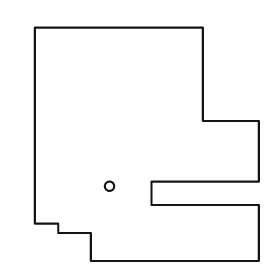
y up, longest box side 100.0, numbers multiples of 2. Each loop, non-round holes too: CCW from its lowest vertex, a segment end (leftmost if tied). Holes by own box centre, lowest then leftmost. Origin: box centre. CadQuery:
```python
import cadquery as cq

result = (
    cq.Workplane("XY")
    .moveTo(-24.0, -50.0)
    .lineTo(48.0, -50.0)
    .lineTo(48.0, -26.0)
    .lineTo(2.0, -26.0)
    .lineTo(2.0, -16.0)
    .lineTo(48.0, -16.0)
    .lineTo(48.0, 10.0)
    .lineTo(24.0, 10.0)
    .lineTo(24.0, 50.0)
    .lineTo(-48.0, 50.0)
    .lineTo(-48.0, -34.0)
    .lineTo(-38.0, -34.0)
    .lineTo(-38.0, -38.0)
    .lineTo(-24.0, -38.0)
    .close()
    .moveTo(-16.0, -18.0)
    .circle(2.0)
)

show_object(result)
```